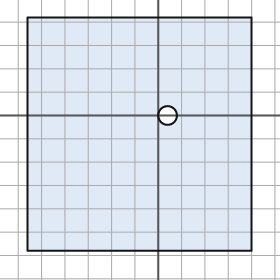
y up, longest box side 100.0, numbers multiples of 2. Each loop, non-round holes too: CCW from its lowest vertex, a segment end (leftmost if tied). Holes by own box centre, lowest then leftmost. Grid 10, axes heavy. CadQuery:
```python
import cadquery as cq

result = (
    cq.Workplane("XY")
    .moveTo(-56.0, -58.0)
    .lineTo(40.0, -58.0)
    .lineTo(40.0, 42.0)
    .lineTo(-56.0, 42.0)
    .close()
    .moveTo(4.0, 0.0)
    .circle(4.0)
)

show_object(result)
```